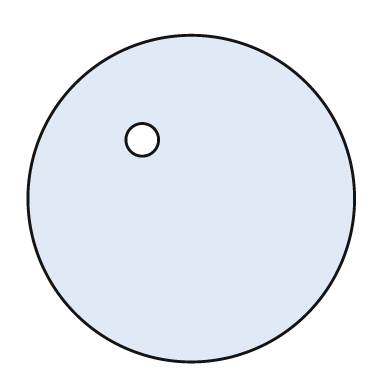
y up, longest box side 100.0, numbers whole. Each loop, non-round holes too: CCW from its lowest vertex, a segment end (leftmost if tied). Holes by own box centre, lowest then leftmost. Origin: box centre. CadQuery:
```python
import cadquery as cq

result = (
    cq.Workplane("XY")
    .moveTo(0.0, 0.0)
    .circle(50.0)
    .moveTo(-15.0, 18.0)
    .circle(5.0)
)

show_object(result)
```